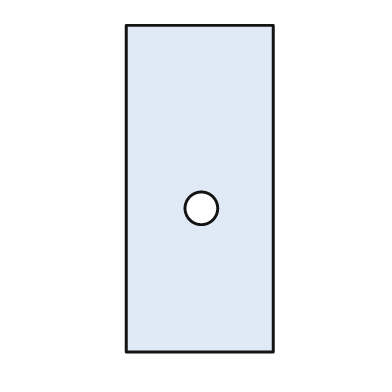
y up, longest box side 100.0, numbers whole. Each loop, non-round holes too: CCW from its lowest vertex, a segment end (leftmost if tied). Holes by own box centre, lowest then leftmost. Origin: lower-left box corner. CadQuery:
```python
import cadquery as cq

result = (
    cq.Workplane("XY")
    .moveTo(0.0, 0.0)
    .lineTo(45.0, 0.0)
    .lineTo(45.0, 100.0)
    .lineTo(0.0, 100.0)
    .close()
    .moveTo(23.0, 44.0)
    .circle(5.0)
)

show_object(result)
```